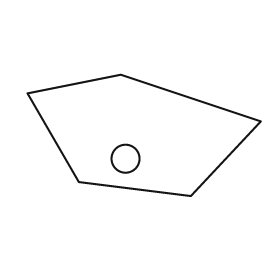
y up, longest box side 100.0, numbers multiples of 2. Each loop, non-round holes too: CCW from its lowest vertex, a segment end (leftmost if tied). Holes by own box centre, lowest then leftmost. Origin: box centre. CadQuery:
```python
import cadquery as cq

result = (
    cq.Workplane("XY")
    .moveTo(20.0, -26.0)
    .lineTo(50.0, 6.0)
    .lineTo(-10.0, 26.0)
    .lineTo(-50.0, 18.0)
    .lineTo(-28.0, -20.0)
    .close()
    .moveTo(-8.0, -10.0)
    .circle(6.0)
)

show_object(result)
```